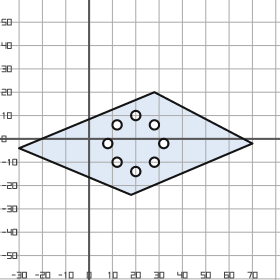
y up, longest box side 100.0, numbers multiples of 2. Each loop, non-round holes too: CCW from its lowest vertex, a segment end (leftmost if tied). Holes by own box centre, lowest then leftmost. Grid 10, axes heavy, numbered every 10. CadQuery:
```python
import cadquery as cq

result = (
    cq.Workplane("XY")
    .moveTo(18.0, -24.0)
    .lineTo(70.0, -2.0)
    .lineTo(28.0, 20.0)
    .lineTo(-30.0, -4.0)
    .close()
    .moveTo(20.0, -14.0)
    .circle(2.0)
    .moveTo(12.0, -10.0)
    .circle(2.0)
    .moveTo(28.0, -10.0)
    .circle(2.0)
    .moveTo(8.0, -2.0)
    .circle(2.0)
    .moveTo(32.0, -2.0)
    .circle(2.0)
    .moveTo(12.0, 6.0)
    .circle(2.0)
    .moveTo(28.0, 6.0)
    .circle(2.0)
    .moveTo(20.0, 10.0)
    .circle(2.0)
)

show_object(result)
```